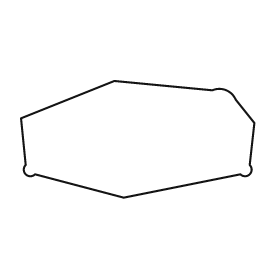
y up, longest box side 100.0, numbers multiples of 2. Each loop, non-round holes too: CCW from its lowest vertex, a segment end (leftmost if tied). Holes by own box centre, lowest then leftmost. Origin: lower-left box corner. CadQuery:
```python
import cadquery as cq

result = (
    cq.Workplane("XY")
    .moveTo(44.0, 0.0)
    .lineTo(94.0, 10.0)
    .threePointArc((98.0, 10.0), (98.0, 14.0))
    .lineTo(100.0, 32.0)
    .lineTo(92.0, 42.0)
    .threePointArc((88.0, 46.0), (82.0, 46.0))
    .lineTo(40.0, 50.0)
    .lineTo(0.0, 34.0)
    .lineTo(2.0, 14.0)
    .threePointArc((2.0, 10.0), (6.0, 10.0))
    .close()
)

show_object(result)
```